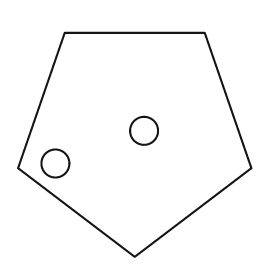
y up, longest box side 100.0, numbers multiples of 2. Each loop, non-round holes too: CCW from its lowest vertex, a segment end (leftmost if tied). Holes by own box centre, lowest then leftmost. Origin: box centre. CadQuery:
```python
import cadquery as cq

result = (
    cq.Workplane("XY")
    .moveTo(0.0, -48.0)
    .lineTo(50.0, -10.0)
    .lineTo(30.0, 48.0)
    .lineTo(-30.0, 48.0)
    .lineTo(-50.0, -10.0)
    .close()
    .moveTo(-34.0, -8.0)
    .circle(6.0)
    .moveTo(4.0, 6.0)
    .circle(6.0)
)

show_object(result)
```